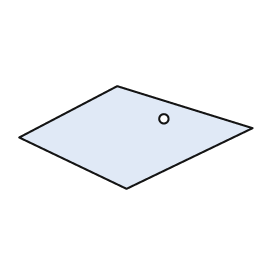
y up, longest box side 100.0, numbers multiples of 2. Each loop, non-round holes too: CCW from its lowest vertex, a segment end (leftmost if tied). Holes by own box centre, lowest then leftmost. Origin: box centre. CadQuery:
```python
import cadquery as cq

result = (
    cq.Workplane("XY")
    .moveTo(-4.0, -22.0)
    .lineTo(50.0, 4.0)
    .lineTo(-8.0, 22.0)
    .lineTo(-50.0, 0.0)
    .close()
    .moveTo(12.0, 8.0)
    .circle(2.0)
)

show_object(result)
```